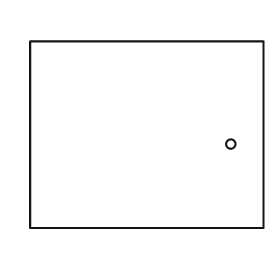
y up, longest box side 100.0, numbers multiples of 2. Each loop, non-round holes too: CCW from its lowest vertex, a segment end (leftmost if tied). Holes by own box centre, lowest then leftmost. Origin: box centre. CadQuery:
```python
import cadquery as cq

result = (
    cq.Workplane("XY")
    .moveTo(-50.0, -40.0)
    .lineTo(50.0, -40.0)
    .lineTo(50.0, 40.0)
    .lineTo(-50.0, 40.0)
    .close()
    .moveTo(36.0, -4.0)
    .circle(2.0)
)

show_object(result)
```